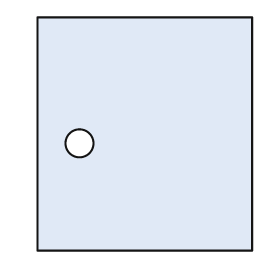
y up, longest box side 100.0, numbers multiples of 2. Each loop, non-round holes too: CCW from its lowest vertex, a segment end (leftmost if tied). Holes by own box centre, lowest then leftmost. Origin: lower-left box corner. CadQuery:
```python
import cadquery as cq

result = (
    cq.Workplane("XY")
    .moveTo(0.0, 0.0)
    .lineTo(92.0, 0.0)
    .lineTo(92.0, 100.0)
    .lineTo(0.0, 100.0)
    .close()
    .moveTo(18.0, 46.0)
    .circle(6.0)
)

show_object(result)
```